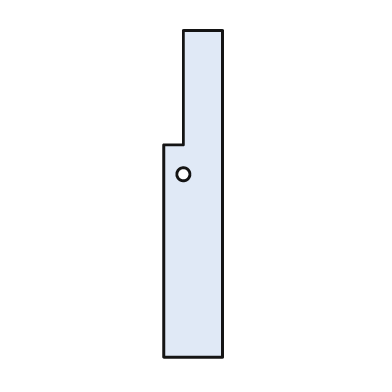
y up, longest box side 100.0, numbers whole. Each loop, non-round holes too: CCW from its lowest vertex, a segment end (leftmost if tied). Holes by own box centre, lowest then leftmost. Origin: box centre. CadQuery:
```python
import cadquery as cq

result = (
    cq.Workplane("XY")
    .moveTo(-9.0, -50.0)
    .lineTo(9.0, -50.0)
    .lineTo(9.0, 50.0)
    .lineTo(-3.0, 50.0)
    .lineTo(-3.0, 15.0)
    .lineTo(-9.0, 15.0)
    .close()
    .moveTo(-3.0, 6.0)
    .circle(2.0)
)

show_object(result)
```